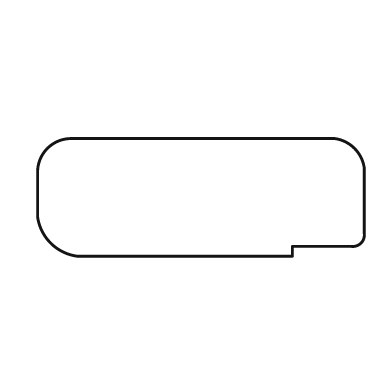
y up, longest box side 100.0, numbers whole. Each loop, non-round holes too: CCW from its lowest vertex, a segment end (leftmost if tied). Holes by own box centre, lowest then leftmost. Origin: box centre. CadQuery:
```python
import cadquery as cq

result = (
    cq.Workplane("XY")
    .moveTo(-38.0, -18.0)
    .lineTo(28.0, -18.0)
    .lineTo(28.0, -15.0)
    .lineTo(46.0, -15.0)
    .threePointArc((49.0, -14.0), (50.0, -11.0))
    .lineTo(50.0, 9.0)
    .threePointArc((47.0, 15.0), (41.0, 18.0))
    .lineTo(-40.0, 18.0)
    .threePointArc((-47.0, 15.0), (-50.0, 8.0))
    .lineTo(-50.0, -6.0)
    .threePointArc((-46.0, -14.0), (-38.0, -18.0))
    .close()
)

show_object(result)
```